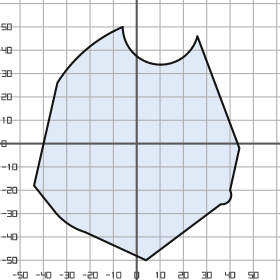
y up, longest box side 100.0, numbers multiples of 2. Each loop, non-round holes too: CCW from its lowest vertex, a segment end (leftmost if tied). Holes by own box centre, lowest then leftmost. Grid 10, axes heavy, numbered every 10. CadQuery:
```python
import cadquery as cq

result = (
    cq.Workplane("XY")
    .moveTo(4.0, -50.0)
    .lineTo(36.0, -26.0)
    .threePointArc((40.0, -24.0), (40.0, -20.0))
    .lineTo(44.0, -2.0)
    .lineTo(26.0, 46.0)
    .threePointArc((8.0, 34.0), (-6.0, 50.0))
    .threePointArc((-22.0, 40.0), (-34.0, 26.0))
    .lineTo(-44.0, -18.0)
    .lineTo(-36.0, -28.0)
    .threePointArc((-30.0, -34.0), (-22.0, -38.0))
    .close()
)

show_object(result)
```